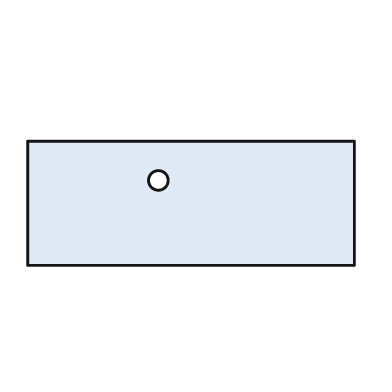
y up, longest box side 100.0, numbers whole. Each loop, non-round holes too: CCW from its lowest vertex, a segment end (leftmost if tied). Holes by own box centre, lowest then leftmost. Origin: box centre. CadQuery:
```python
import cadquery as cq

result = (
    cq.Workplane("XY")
    .moveTo(-50.0, -19.0)
    .lineTo(50.0, -19.0)
    .lineTo(50.0, 19.0)
    .lineTo(-50.0, 19.0)
    .close()
    .moveTo(-10.0, 7.0)
    .circle(3.0)
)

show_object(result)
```